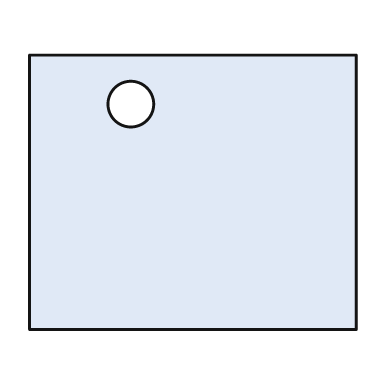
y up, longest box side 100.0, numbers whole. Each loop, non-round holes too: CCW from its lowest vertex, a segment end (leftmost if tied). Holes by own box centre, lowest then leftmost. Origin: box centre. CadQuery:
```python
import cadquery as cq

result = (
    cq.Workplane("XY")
    .moveTo(-50.0, -42.0)
    .lineTo(50.0, -42.0)
    .lineTo(50.0, 42.0)
    .lineTo(-50.0, 42.0)
    .close()
    .moveTo(-19.0, 27.0)
    .circle(7.0)
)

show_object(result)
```